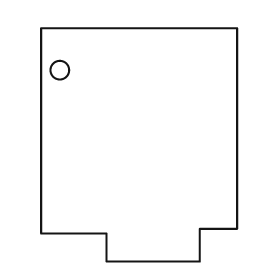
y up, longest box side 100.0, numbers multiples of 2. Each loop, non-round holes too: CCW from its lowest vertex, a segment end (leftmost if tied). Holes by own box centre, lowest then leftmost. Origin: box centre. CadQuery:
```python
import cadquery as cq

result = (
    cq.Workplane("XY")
    .moveTo(-14.0, -50.0)
    .lineTo(26.0, -50.0)
    .lineTo(26.0, -36.0)
    .lineTo(42.0, -36.0)
    .lineTo(42.0, 50.0)
    .lineTo(-42.0, 50.0)
    .lineTo(-42.0, -38.0)
    .lineTo(-14.0, -38.0)
    .close()
    .moveTo(-34.0, 32.0)
    .circle(4.0)
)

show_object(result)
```